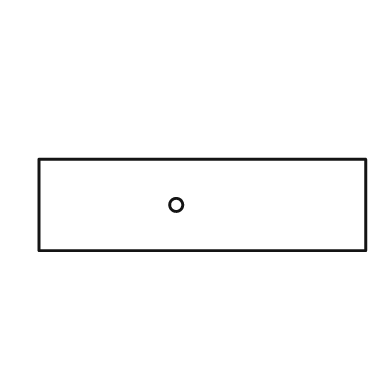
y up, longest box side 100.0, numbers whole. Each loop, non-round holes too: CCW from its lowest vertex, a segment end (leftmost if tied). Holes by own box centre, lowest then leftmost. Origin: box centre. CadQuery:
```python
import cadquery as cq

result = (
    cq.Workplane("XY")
    .moveTo(-50.0, -14.0)
    .lineTo(50.0, -14.0)
    .lineTo(50.0, 14.0)
    .lineTo(-50.0, 14.0)
    .close()
    .moveTo(-8.0, 0.0)
    .circle(2.0)
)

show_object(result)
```